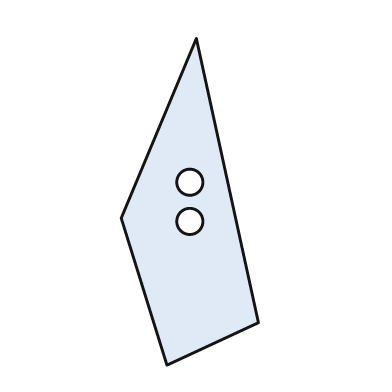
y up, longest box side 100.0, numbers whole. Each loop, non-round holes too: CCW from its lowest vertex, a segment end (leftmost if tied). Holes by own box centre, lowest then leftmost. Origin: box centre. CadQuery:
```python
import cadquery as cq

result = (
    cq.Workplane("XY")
    .moveTo(-7.0, -50.0)
    .lineTo(21.0, -37.0)
    .lineTo(2.0, 50.0)
    .lineTo(-21.0, -5.0)
    .close()
    .moveTo(0.0, -6.0)
    .circle(4.0)
    .moveTo(0.0, 6.0)
    .circle(4.0)
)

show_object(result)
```